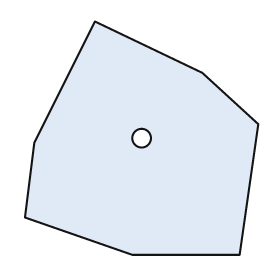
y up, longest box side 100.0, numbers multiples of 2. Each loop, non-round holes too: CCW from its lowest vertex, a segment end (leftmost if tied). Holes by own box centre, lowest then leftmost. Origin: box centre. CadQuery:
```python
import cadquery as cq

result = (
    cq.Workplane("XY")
    .moveTo(-4.0, -50.0)
    .lineTo(42.0, -50.0)
    .lineTo(50.0, 6.0)
    .lineTo(26.0, 28.0)
    .lineTo(-20.0, 50.0)
    .lineTo(-46.0, -2.0)
    .lineTo(-50.0, -34.0)
    .close()
    .moveTo(0.0, 0.0)
    .circle(4.0)
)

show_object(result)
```